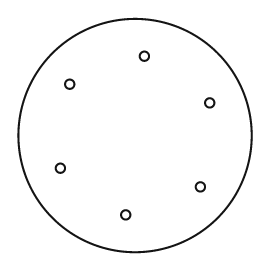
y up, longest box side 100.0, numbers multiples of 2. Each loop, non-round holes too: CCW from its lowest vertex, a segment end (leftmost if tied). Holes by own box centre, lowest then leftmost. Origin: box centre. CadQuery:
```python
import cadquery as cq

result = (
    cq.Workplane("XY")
    .moveTo(0.0, 0.0)
    .circle(50.0)
    .moveTo(-4.0, -34.0)
    .circle(2.0)
    .moveTo(28.0, -22.0)
    .circle(2.0)
    .moveTo(-32.0, -14.0)
    .circle(2.0)
    .moveTo(32.0, 14.0)
    .circle(2.0)
    .moveTo(-28.0, 22.0)
    .circle(2.0)
    .moveTo(4.0, 34.0)
    .circle(2.0)
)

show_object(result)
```